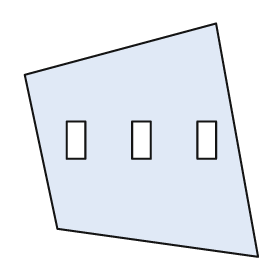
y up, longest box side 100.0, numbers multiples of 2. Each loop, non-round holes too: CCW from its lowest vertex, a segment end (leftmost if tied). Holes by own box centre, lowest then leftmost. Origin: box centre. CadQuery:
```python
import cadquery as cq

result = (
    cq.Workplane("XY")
    .moveTo(50.0, -50.0)
    .lineTo(32.0, 50.0)
    .lineTo(-50.0, 28.0)
    .lineTo(-36.0, -38.0)
    .close()
    .moveTo(-32.0, -8.0)
    .lineTo(-24.0, -8.0)
    .lineTo(-24.0, 8.0)
    .lineTo(-32.0, 8.0)
    .close()
    .moveTo(-4.0, -8.0)
    .lineTo(4.0, -8.0)
    .lineTo(4.0, 8.0)
    .lineTo(-4.0, 8.0)
    .close()
    .moveTo(24.0, -8.0)
    .lineTo(32.0, -8.0)
    .lineTo(32.0, 8.0)
    .lineTo(24.0, 8.0)
    .close()
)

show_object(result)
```